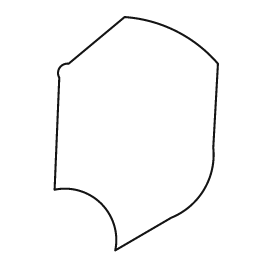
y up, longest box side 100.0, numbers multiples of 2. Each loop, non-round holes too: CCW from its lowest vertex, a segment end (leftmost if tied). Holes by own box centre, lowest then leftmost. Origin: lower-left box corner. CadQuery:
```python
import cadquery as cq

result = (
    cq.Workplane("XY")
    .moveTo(26.0, 0.0)
    .lineTo(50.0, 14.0)
    .threePointArc((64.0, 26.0), (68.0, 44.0))
    .lineTo(70.0, 80.0)
    .threePointArc((52.0, 94.0), (30.0, 100.0))
    .lineTo(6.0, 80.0)
    .threePointArc((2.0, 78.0), (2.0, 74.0))
    .lineTo(0.0, 26.0)
    .threePointArc((20.0, 20.0), (26.0, 0.0))
    .close()
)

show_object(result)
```